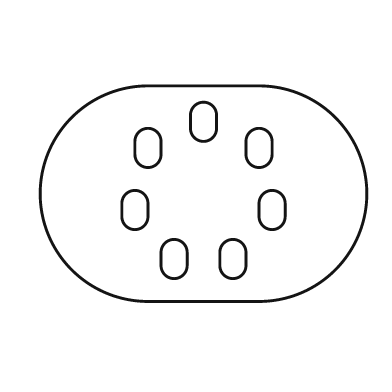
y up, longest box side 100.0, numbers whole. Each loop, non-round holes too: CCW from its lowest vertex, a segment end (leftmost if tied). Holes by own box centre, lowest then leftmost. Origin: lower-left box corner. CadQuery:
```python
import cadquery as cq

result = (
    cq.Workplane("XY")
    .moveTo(33.0, 0.0)
    .lineTo(67.0, 0.0)
    .threePointArc((100.0, 33.0), (67.0, 66.0))
    .lineTo(33.0, 66.0)
    .threePointArc((0.0, 33.0), (33.0, 0.0))
    .close()
    .moveTo(37.0, 11.0)
    .threePointArc((41.0, 7.0), (45.0, 11.0))
    .lineTo(45.0, 15.0)
    .threePointArc((41.0, 19.0), (37.0, 15.0))
    .close()
    .moveTo(55.0, 11.0)
    .threePointArc((59.0, 7.0), (63.0, 11.0))
    .lineTo(63.0, 15.0)
    .threePointArc((59.0, 19.0), (55.0, 15.0))
    .close()
    .moveTo(25.0, 26.0)
    .threePointArc((29.0, 22.0), (33.0, 26.0))
    .lineTo(33.0, 30.0)
    .threePointArc((29.0, 34.0), (25.0, 30.0))
    .close()
    .moveTo(67.0, 26.0)
    .threePointArc((71.0, 22.0), (75.0, 26.0))
    .lineTo(75.0, 30.0)
    .threePointArc((71.0, 34.0), (67.0, 30.0))
    .close()
    .moveTo(29.0, 45.0)
    .threePointArc((33.0, 41.0), (37.0, 45.0))
    .lineTo(37.0, 49.0)
    .threePointArc((33.0, 53.0), (29.0, 49.0))
    .close()
    .moveTo(63.0, 45.0)
    .threePointArc((67.0, 41.0), (71.0, 45.0))
    .lineTo(71.0, 49.0)
    .threePointArc((67.0, 53.0), (63.0, 49.0))
    .close()
    .moveTo(46.0, 53.0)
    .threePointArc((50.0, 49.0), (54.0, 53.0))
    .lineTo(54.0, 57.0)
    .threePointArc((50.0, 61.0), (46.0, 57.0))
    .close()
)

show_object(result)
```